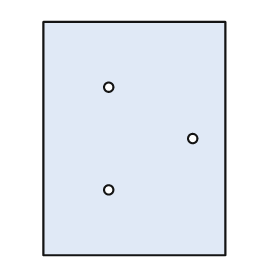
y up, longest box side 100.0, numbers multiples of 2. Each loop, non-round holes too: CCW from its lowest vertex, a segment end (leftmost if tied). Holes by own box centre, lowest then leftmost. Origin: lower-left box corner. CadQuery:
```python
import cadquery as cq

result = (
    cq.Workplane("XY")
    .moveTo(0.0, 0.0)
    .lineTo(78.0, 0.0)
    .lineTo(78.0, 100.0)
    .lineTo(0.0, 100.0)
    .close()
    .moveTo(28.0, 28.0)
    .circle(2.0)
    .moveTo(64.0, 50.0)
    .circle(2.0)
    .moveTo(28.0, 72.0)
    .circle(2.0)
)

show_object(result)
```